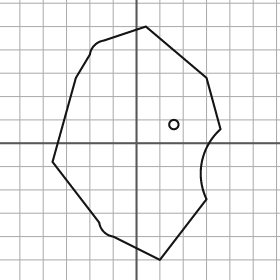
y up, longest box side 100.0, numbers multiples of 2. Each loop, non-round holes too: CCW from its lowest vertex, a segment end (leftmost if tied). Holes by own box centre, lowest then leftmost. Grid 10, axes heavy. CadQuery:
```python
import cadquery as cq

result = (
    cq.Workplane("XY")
    .moveTo(10.0, -50.0)
    .lineTo(30.0, -24.0)
    .threePointArc((28.0, -8.0), (36.0, 6.0))
    .lineTo(30.0, 28.0)
    .lineTo(4.0, 50.0)
    .lineTo(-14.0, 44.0)
    .threePointArc((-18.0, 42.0), (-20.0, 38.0))
    .lineTo(-26.0, 28.0)
    .lineTo(-36.0, -8.0)
    .lineTo(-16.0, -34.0)
    .threePointArc((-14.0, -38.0), (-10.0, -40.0))
    .close()
    .moveTo(16.0, 8.0)
    .circle(2.0)
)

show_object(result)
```